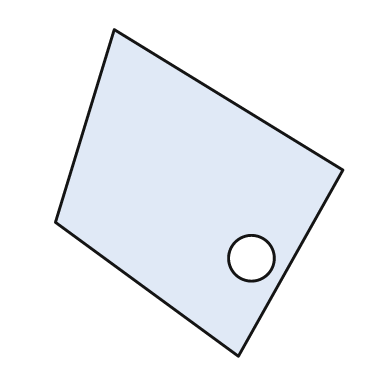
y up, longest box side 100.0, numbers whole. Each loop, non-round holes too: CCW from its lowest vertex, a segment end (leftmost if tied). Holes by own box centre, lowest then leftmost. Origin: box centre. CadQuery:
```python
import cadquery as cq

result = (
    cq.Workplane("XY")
    .moveTo(12.0, -50.0)
    .lineTo(44.0, 7.0)
    .lineTo(-26.0, 50.0)
    .lineTo(-44.0, -9.0)
    .close()
    .moveTo(16.0, -20.0)
    .circle(7.0)
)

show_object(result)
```